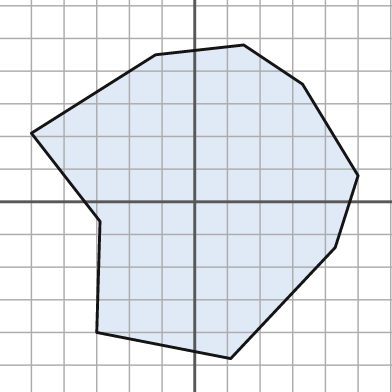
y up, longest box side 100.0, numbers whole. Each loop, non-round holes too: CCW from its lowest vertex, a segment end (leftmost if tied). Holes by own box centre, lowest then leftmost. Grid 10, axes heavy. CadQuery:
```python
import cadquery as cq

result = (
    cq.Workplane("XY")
    .moveTo(11.0, -48.0)
    .lineTo(43.0, -14.0)
    .lineTo(50.0, 8.0)
    .lineTo(33.0, 36.0)
    .lineTo(15.0, 48.0)
    .lineTo(-12.0, 45.0)
    .lineTo(-50.0, 21.0)
    .lineTo(-29.0, -6.0)
    .lineTo(-30.0, -40.0)
    .close()
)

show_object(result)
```